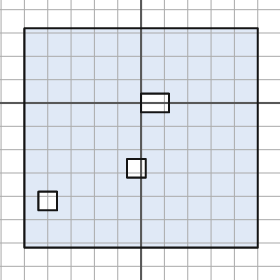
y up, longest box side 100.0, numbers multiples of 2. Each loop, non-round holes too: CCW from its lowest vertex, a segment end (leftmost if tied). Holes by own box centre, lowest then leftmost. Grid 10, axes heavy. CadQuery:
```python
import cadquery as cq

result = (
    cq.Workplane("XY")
    .moveTo(-50.0, -62.0)
    .lineTo(50.0, -62.0)
    .lineTo(50.0, 32.0)
    .lineTo(-50.0, 32.0)
    .close()
    .moveTo(-44.0, -46.0)
    .lineTo(-36.0, -46.0)
    .lineTo(-36.0, -38.0)
    .lineTo(-44.0, -38.0)
    .close()
    .moveTo(-6.0, -32.0)
    .lineTo(2.0, -32.0)
    .lineTo(2.0, -24.0)
    .lineTo(-6.0, -24.0)
    .close()
    .moveTo(0.0, -4.0)
    .lineTo(12.0, -4.0)
    .lineTo(12.0, 4.0)
    .lineTo(0.0, 4.0)
    .close()
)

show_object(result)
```